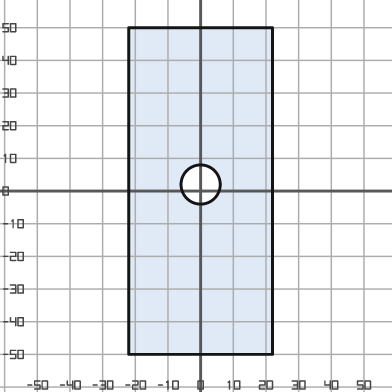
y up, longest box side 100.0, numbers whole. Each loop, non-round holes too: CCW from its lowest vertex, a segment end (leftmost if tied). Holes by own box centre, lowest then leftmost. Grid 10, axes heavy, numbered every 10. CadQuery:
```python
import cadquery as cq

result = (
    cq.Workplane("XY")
    .moveTo(-22.0, -50.0)
    .lineTo(22.0, -50.0)
    .lineTo(22.0, 50.0)
    .lineTo(-22.0, 50.0)
    .close()
    .moveTo(0.0, 2.0)
    .circle(6.0)
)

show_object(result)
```